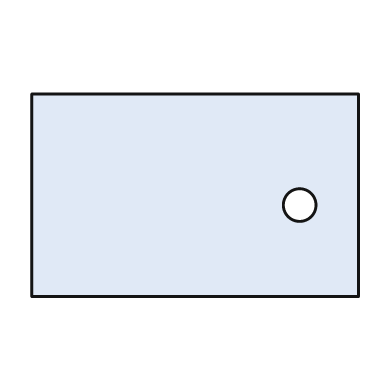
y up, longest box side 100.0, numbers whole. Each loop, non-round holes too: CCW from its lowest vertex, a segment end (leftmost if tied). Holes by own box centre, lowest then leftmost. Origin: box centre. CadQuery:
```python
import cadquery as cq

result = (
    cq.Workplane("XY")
    .moveTo(-50.0, -31.0)
    .lineTo(50.0, -31.0)
    .lineTo(50.0, 31.0)
    .lineTo(-50.0, 31.0)
    .close()
    .moveTo(32.0, -3.0)
    .circle(5.0)
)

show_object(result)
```